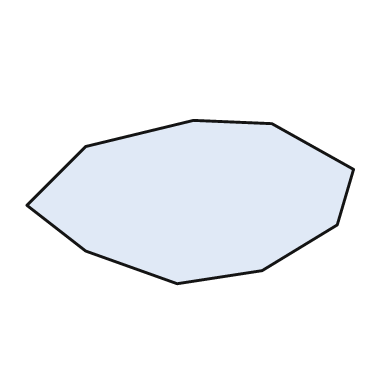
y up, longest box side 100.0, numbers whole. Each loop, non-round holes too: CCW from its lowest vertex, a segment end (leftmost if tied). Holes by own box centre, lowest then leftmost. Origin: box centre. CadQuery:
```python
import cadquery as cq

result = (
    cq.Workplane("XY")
    .moveTo(-4.0, -25.0)
    .lineTo(22.0, -21.0)
    .lineTo(45.0, -7.0)
    .lineTo(50.0, 10.0)
    .lineTo(25.0, 24.0)
    .lineTo(1.0, 25.0)
    .lineTo(-32.0, 17.0)
    .lineTo(-50.0, -1.0)
    .lineTo(-32.0, -15.0)
    .close()
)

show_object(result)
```